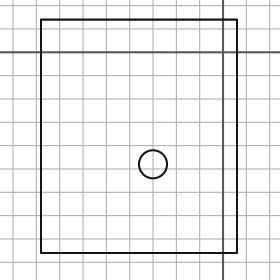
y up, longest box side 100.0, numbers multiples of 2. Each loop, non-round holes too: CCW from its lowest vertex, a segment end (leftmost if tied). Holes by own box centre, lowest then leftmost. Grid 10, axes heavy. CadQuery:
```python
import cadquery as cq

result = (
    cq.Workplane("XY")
    .moveTo(-78.0, -86.0)
    .lineTo(6.0, -86.0)
    .lineTo(6.0, 14.0)
    .lineTo(-78.0, 14.0)
    .close()
    .moveTo(-30.0, -48.0)
    .circle(6.0)
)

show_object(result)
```